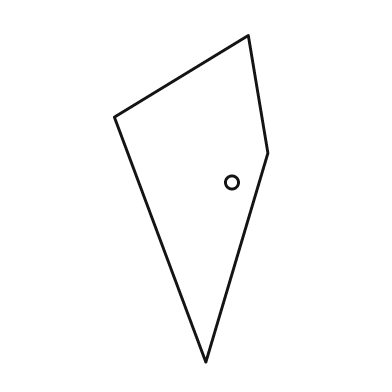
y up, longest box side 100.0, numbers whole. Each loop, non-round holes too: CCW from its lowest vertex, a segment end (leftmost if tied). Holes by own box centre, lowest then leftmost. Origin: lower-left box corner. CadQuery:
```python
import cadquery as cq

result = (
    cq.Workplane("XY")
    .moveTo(28.0, 0.0)
    .lineTo(47.0, 64.0)
    .lineTo(41.0, 100.0)
    .lineTo(0.0, 75.0)
    .close()
    .moveTo(36.0, 55.0)
    .circle(2.0)
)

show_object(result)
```